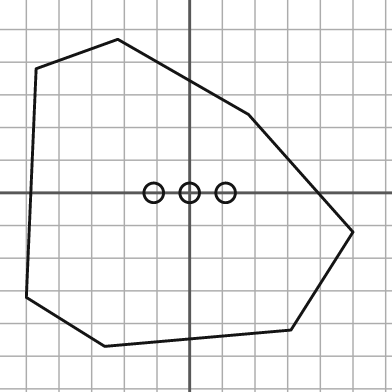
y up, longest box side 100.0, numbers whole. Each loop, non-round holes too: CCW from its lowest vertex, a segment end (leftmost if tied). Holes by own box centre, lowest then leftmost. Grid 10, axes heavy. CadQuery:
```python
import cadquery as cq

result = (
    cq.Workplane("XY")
    .moveTo(-26.0, -47.0)
    .lineTo(31.0, -42.0)
    .lineTo(50.0, -12.0)
    .lineTo(18.0, 24.0)
    .lineTo(-22.0, 47.0)
    .lineTo(-47.0, 38.0)
    .lineTo(-50.0, -32.0)
    .close()
    .moveTo(-11.0, 0.0)
    .circle(3.0)
    .moveTo(0.0, 0.0)
    .circle(3.0)
    .moveTo(11.0, 0.0)
    .circle(3.0)
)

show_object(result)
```